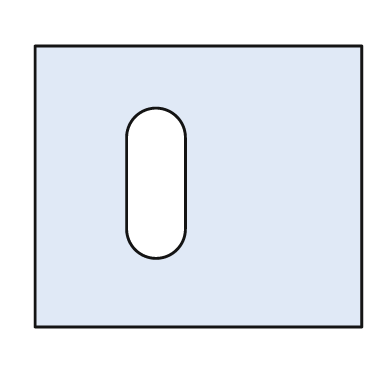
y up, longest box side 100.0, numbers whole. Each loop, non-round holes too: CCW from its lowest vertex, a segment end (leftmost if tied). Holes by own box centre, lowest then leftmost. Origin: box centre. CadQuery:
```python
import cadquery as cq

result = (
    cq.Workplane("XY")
    .moveTo(-50.0, -43.0)
    .lineTo(50.0, -43.0)
    .lineTo(50.0, 43.0)
    .lineTo(-50.0, 43.0)
    .close()
    .moveTo(-22.0, -13.0)
    .threePointArc((-13.0, -22.0), (-4.0, -13.0))
    .lineTo(-4.0, 15.0)
    .threePointArc((-13.0, 24.0), (-22.0, 15.0))
    .close()
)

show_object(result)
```